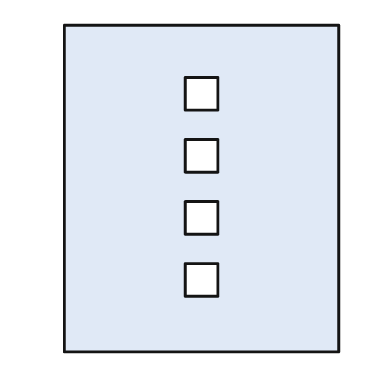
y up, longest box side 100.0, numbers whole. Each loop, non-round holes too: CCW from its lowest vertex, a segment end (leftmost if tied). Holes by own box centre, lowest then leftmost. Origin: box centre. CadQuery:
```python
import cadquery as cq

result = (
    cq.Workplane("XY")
    .moveTo(-42.0, -50.0)
    .lineTo(42.0, -50.0)
    .lineTo(42.0, 50.0)
    .lineTo(-42.0, 50.0)
    .close()
    .moveTo(-5.0, -33.0)
    .lineTo(5.0, -33.0)
    .lineTo(5.0, -23.0)
    .lineTo(-5.0, -23.0)
    .close()
    .moveTo(-5.0, -14.0)
    .lineTo(5.0, -14.0)
    .lineTo(5.0, -4.0)
    .lineTo(-5.0, -4.0)
    .close()
    .moveTo(-5.0, 5.0)
    .lineTo(5.0, 5.0)
    .lineTo(5.0, 15.0)
    .lineTo(-5.0, 15.0)
    .close()
    .moveTo(-5.0, 24.0)
    .lineTo(5.0, 24.0)
    .lineTo(5.0, 34.0)
    .lineTo(-5.0, 34.0)
    .close()
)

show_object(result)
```